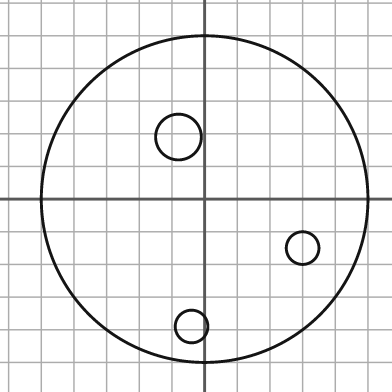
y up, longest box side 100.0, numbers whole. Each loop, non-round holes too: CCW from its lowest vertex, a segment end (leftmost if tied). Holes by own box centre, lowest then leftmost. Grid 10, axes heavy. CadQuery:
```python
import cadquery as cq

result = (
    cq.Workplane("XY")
    .moveTo(0.0, 0.0)
    .circle(50.0)
    .moveTo(-4.0, -39.0)
    .circle(5.0)
    .moveTo(30.0, -15.0)
    .circle(5.0)
    .moveTo(-8.0, 19.0)
    .circle(7.0)
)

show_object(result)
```